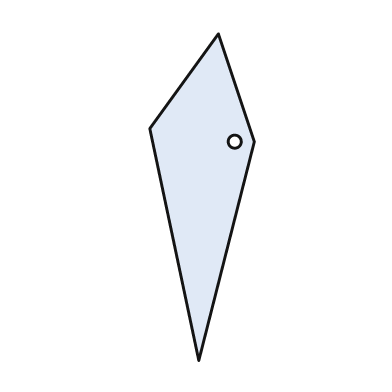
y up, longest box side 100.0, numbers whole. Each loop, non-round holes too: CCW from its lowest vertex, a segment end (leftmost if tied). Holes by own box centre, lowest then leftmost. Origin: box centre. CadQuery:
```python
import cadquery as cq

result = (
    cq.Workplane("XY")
    .moveTo(-1.0, -50.0)
    .lineTo(16.0, 17.0)
    .lineTo(5.0, 50.0)
    .lineTo(-16.0, 21.0)
    .close()
    .moveTo(10.0, 17.0)
    .circle(2.0)
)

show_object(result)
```